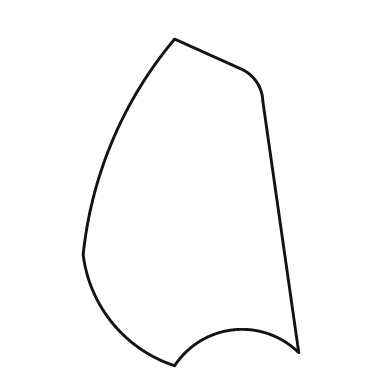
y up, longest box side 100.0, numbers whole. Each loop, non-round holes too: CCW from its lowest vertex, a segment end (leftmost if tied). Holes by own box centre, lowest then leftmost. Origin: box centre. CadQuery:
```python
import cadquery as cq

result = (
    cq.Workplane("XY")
    .moveTo(-5.0, -50.0)
    .threePointArc((13.0, -39.0), (33.0, -46.0))
    .lineTo(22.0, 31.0)
    .threePointArc((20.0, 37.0), (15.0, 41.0))
    .lineTo(-5.0, 50.0)
    .threePointArc((-24.0, 19.0), (-33.0, -16.0))
    .threePointArc((-24.0, -37.0), (-5.0, -50.0))
    .close()
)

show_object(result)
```